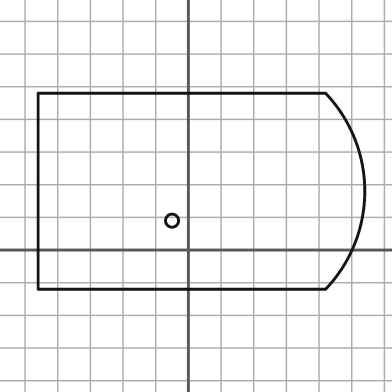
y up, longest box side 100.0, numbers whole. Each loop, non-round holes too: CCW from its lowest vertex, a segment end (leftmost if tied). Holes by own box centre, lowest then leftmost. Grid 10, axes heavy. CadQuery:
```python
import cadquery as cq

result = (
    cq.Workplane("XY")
    .moveTo(-46.0, -12.0)
    .lineTo(42.0, -12.0)
    .threePointArc((54.0, 18.0), (42.0, 48.0))
    .lineTo(-46.0, 48.0)
    .close()
    .moveTo(-5.0, 9.0)
    .circle(2.0)
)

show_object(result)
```